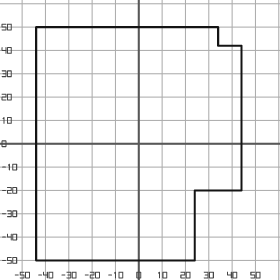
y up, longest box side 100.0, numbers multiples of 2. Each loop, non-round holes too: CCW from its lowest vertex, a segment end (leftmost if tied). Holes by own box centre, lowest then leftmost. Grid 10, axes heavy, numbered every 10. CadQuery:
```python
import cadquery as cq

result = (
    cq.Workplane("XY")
    .moveTo(-44.0, -50.0)
    .lineTo(24.0, -50.0)
    .lineTo(24.0, -20.0)
    .lineTo(44.0, -20.0)
    .lineTo(44.0, 42.0)
    .lineTo(34.0, 42.0)
    .lineTo(34.0, 50.0)
    .lineTo(-44.0, 50.0)
    .close()
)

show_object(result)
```